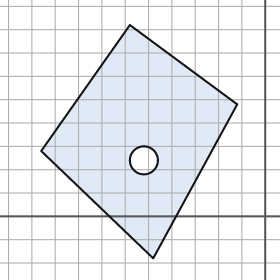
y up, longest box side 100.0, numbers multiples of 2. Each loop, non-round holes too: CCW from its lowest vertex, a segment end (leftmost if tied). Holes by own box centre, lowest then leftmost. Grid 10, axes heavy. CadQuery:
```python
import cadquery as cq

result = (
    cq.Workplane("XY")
    .moveTo(-48.0, -18.0)
    .lineTo(-12.0, 48.0)
    .lineTo(-58.0, 82.0)
    .lineTo(-96.0, 28.0)
    .close()
    .moveTo(-52.0, 24.0)
    .circle(6.0)
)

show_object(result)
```